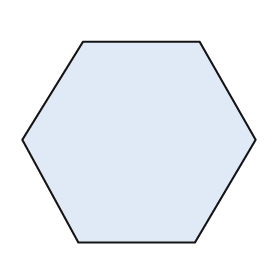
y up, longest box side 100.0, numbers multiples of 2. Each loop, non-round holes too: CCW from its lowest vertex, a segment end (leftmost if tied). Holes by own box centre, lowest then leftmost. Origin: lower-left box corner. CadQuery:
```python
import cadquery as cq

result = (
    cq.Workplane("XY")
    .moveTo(24.0, 0.0)
    .lineTo(74.0, 0.0)
    .lineTo(100.0, 44.0)
    .lineTo(76.0, 86.0)
    .lineTo(26.0, 86.0)
    .lineTo(0.0, 44.0)
    .close()
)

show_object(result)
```